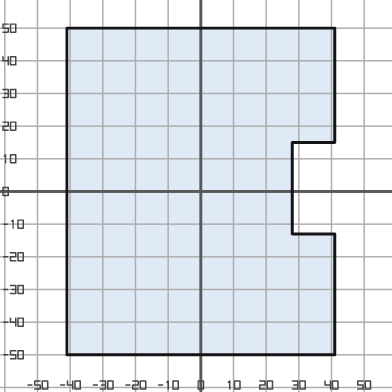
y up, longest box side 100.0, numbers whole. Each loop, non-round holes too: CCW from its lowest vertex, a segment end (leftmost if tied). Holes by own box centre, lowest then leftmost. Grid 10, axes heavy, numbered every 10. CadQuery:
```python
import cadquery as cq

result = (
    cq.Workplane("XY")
    .moveTo(-41.0, -50.0)
    .lineTo(41.0, -50.0)
    .lineTo(41.0, -13.0)
    .lineTo(28.0, -13.0)
    .lineTo(28.0, 15.0)
    .lineTo(41.0, 15.0)
    .lineTo(41.0, 50.0)
    .lineTo(-41.0, 50.0)
    .close()
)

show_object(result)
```